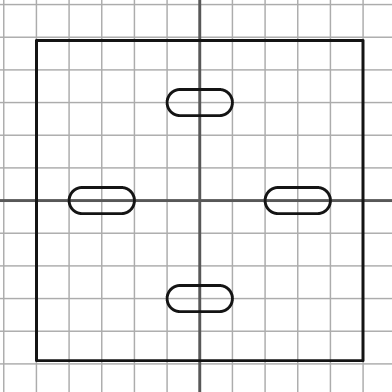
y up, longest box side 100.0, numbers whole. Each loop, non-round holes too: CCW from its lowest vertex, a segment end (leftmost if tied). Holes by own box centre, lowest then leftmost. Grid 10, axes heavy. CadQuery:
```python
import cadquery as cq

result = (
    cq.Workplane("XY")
    .moveTo(-50.0, -49.0)
    .lineTo(50.0, -49.0)
    .lineTo(50.0, 49.0)
    .lineTo(-50.0, 49.0)
    .close()
    .moveTo(-6.0, -34.0)
    .lineTo(6.0, -34.0)
    .threePointArc((10.0, -30.0), (6.0, -26.0))
    .lineTo(-6.0, -26.0)
    .threePointArc((-10.0, -30.0), (-6.0, -34.0))
    .close()
    .moveTo(-36.0, -4.0)
    .lineTo(-24.0, -4.0)
    .threePointArc((-20.0, 0.0), (-24.0, 4.0))
    .lineTo(-36.0, 4.0)
    .threePointArc((-40.0, 0.0), (-36.0, -4.0))
    .close()
    .moveTo(24.0, -4.0)
    .lineTo(36.0, -4.0)
    .threePointArc((40.0, 0.0), (36.0, 4.0))
    .lineTo(24.0, 4.0)
    .threePointArc((20.0, 0.0), (24.0, -4.0))
    .close()
    .moveTo(-6.0, 26.0)
    .lineTo(6.0, 26.0)
    .threePointArc((10.0, 30.0), (6.0, 34.0))
    .lineTo(-6.0, 34.0)
    .threePointArc((-10.0, 30.0), (-6.0, 26.0))
    .close()
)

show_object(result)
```